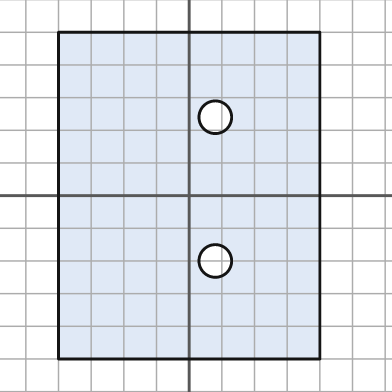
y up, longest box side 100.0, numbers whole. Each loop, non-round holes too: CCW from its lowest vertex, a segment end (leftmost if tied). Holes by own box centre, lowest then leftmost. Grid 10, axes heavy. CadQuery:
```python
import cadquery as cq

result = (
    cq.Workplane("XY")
    .moveTo(-40.0, -50.0)
    .lineTo(40.0, -50.0)
    .lineTo(40.0, 50.0)
    .lineTo(-40.0, 50.0)
    .close()
    .moveTo(8.0, -20.0)
    .circle(5.0)
    .moveTo(8.0, 24.0)
    .circle(5.0)
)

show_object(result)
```